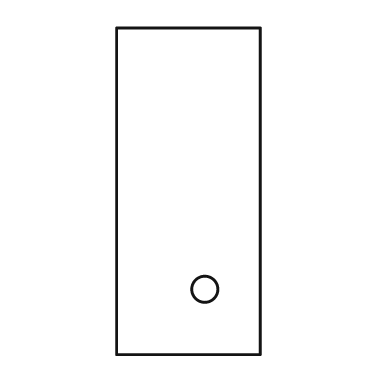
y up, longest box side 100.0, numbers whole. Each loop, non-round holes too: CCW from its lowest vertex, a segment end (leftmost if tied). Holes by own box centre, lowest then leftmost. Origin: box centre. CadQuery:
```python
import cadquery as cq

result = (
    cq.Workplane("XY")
    .moveTo(-22.0, -50.0)
    .lineTo(22.0, -50.0)
    .lineTo(22.0, 50.0)
    .lineTo(-22.0, 50.0)
    .close()
    .moveTo(5.0, -30.0)
    .circle(4.0)
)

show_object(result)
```